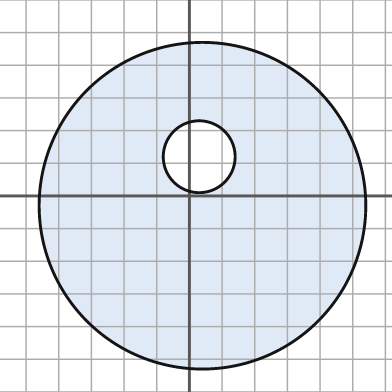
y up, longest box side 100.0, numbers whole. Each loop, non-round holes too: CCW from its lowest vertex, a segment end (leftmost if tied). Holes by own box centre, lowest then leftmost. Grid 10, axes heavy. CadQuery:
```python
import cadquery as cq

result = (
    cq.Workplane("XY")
    .moveTo(4.0, -3.0)
    .circle(50.0)
    .moveTo(3.0, 12.0)
    .circle(11.0)
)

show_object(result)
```